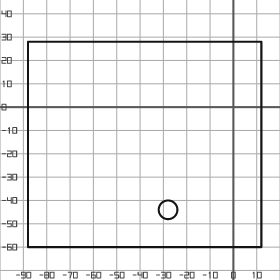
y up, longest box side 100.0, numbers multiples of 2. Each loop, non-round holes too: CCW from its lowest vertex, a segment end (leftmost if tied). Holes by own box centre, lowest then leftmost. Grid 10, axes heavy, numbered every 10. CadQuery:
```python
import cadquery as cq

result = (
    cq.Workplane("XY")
    .moveTo(-88.0, -60.0)
    .lineTo(12.0, -60.0)
    .lineTo(12.0, 28.0)
    .lineTo(-88.0, 28.0)
    .close()
    .moveTo(-28.0, -44.0)
    .circle(4.0)
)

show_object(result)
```